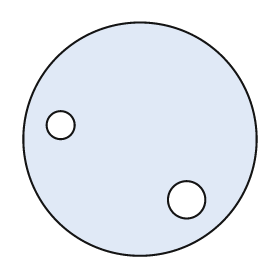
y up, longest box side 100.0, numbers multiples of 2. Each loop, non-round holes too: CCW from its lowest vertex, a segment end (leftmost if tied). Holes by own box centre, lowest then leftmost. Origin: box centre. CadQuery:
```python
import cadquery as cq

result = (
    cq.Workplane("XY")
    .moveTo(0.0, 0.0)
    .circle(50.0)
    .moveTo(20.0, -26.0)
    .circle(8.0)
    .moveTo(-34.0, 6.0)
    .circle(6.0)
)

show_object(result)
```